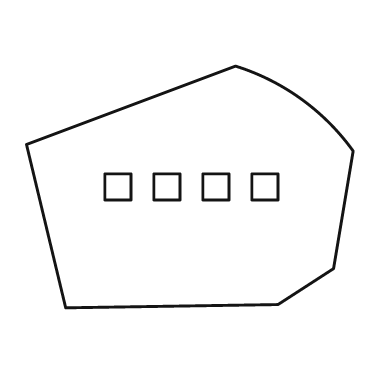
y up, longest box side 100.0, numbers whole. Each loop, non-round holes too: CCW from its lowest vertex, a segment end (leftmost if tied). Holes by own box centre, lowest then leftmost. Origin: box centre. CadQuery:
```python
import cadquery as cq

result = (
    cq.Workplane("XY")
    .moveTo(-38.0, -37.0)
    .lineTo(27.0, -36.0)
    .lineTo(44.0, -25.0)
    .lineTo(50.0, 11.0)
    .threePointArc((34.0, 27.0), (14.0, 37.0))
    .lineTo(-50.0, 13.0)
    .close()
    .moveTo(-26.0, -4.0)
    .lineTo(-18.0, -4.0)
    .lineTo(-18.0, 4.0)
    .lineTo(-26.0, 4.0)
    .close()
    .moveTo(-11.0, -4.0)
    .lineTo(-3.0, -4.0)
    .lineTo(-3.0, 4.0)
    .lineTo(-11.0, 4.0)
    .close()
    .moveTo(4.0, -4.0)
    .lineTo(12.0, -4.0)
    .lineTo(12.0, 4.0)
    .lineTo(4.0, 4.0)
    .close()
    .moveTo(19.0, -4.0)
    .lineTo(27.0, -4.0)
    .lineTo(27.0, 4.0)
    .lineTo(19.0, 4.0)
    .close()
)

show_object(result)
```